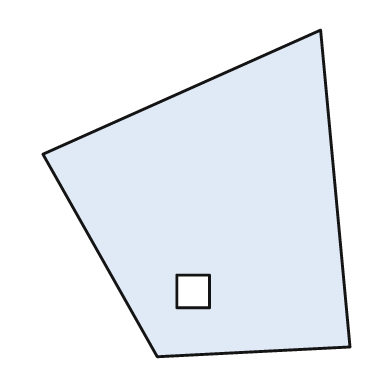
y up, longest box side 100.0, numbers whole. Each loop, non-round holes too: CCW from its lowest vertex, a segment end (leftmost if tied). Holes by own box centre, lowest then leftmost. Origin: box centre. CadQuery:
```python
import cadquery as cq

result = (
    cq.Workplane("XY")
    .moveTo(-12.0, -50.0)
    .lineTo(47.0, -47.0)
    .lineTo(38.0, 50.0)
    .lineTo(-47.0, 12.0)
    .close()
    .moveTo(-6.0, -35.0)
    .lineTo(4.0, -35.0)
    .lineTo(4.0, -25.0)
    .lineTo(-6.0, -25.0)
    .close()
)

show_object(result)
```